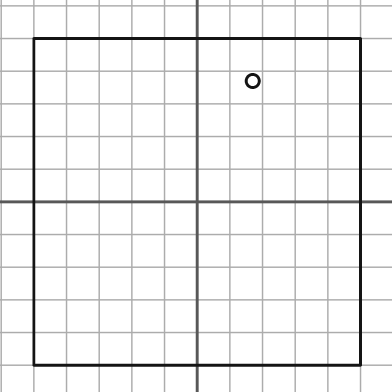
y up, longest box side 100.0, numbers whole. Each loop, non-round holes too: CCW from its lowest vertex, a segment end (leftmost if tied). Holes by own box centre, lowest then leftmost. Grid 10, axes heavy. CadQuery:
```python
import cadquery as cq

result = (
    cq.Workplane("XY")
    .moveTo(-50.0, -50.0)
    .lineTo(50.0, -50.0)
    .lineTo(50.0, 50.0)
    .lineTo(-50.0, 50.0)
    .close()
    .moveTo(17.0, 37.0)
    .circle(2.0)
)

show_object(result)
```